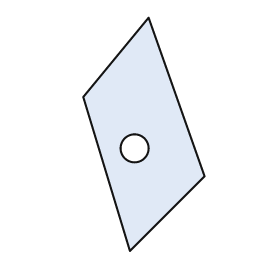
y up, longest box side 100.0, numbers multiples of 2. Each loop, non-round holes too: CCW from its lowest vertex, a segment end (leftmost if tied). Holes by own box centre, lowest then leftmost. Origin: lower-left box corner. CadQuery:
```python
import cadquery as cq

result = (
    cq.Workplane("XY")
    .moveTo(20.0, 0.0)
    .lineTo(52.0, 32.0)
    .lineTo(28.0, 100.0)
    .lineTo(0.0, 66.0)
    .close()
    .moveTo(22.0, 44.0)
    .circle(6.0)
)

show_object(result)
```